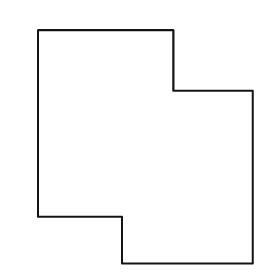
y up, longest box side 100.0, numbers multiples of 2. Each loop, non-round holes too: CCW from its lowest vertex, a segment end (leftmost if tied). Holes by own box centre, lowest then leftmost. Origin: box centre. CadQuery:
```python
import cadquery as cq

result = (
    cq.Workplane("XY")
    .moveTo(-10.0, -50.0)
    .lineTo(46.0, -50.0)
    .lineTo(46.0, 24.0)
    .lineTo(12.0, 24.0)
    .lineTo(12.0, 50.0)
    .lineTo(-46.0, 50.0)
    .lineTo(-46.0, -30.0)
    .lineTo(-10.0, -30.0)
    .close()
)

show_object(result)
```